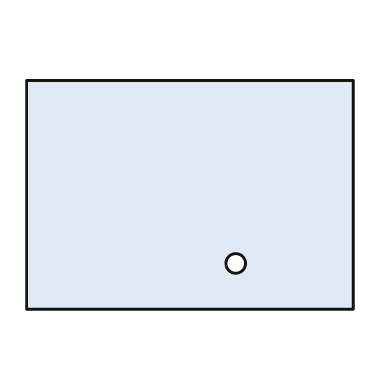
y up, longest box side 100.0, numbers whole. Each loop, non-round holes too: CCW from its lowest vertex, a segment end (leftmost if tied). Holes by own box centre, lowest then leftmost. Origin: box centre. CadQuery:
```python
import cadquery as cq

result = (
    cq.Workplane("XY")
    .moveTo(-50.0, -35.0)
    .lineTo(50.0, -35.0)
    .lineTo(50.0, 35.0)
    .lineTo(-50.0, 35.0)
    .close()
    .moveTo(14.0, -21.0)
    .circle(3.0)
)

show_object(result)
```